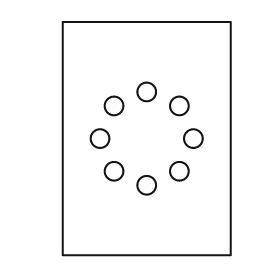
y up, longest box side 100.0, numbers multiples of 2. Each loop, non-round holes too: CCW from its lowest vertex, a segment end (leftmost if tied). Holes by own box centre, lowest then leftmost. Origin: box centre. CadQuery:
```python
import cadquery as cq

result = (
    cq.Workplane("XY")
    .moveTo(-36.0, -50.0)
    .lineTo(36.0, -50.0)
    .lineTo(36.0, 50.0)
    .lineTo(-36.0, 50.0)
    .close()
    .moveTo(0.0, -20.0)
    .circle(4.0)
    .moveTo(-14.0, -14.0)
    .circle(4.0)
    .moveTo(14.0, -14.0)
    .circle(4.0)
    .moveTo(-20.0, 0.0)
    .circle(4.0)
    .moveTo(20.0, 0.0)
    .circle(4.0)
    .moveTo(-14.0, 14.0)
    .circle(4.0)
    .moveTo(14.0, 14.0)
    .circle(4.0)
    .moveTo(0.0, 20.0)
    .circle(4.0)
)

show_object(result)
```